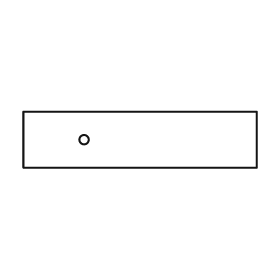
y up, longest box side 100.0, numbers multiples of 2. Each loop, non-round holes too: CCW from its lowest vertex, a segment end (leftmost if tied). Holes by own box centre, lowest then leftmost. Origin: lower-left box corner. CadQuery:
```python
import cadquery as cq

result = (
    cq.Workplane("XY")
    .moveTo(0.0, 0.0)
    .lineTo(100.0, 0.0)
    .lineTo(100.0, 24.0)
    .lineTo(0.0, 24.0)
    .close()
    .moveTo(26.0, 12.0)
    .circle(2.0)
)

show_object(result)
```